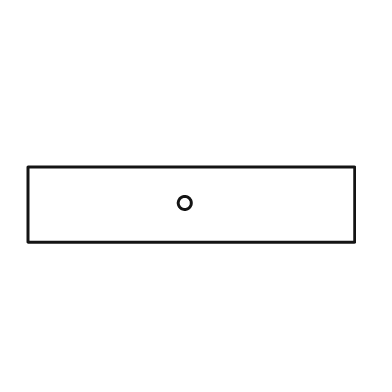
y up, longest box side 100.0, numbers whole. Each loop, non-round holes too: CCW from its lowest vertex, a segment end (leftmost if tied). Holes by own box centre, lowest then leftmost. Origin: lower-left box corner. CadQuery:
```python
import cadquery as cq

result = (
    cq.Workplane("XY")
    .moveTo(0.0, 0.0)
    .lineTo(100.0, 0.0)
    .lineTo(100.0, 23.0)
    .lineTo(0.0, 23.0)
    .close()
    .moveTo(48.0, 12.0)
    .circle(2.0)
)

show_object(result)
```